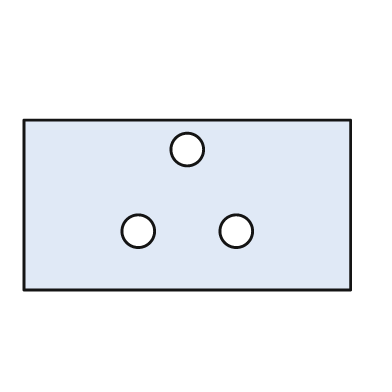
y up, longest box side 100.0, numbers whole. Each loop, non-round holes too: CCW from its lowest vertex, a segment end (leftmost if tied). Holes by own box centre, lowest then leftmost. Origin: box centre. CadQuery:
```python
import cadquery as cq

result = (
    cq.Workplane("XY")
    .moveTo(-50.0, -26.0)
    .lineTo(50.0, -26.0)
    .lineTo(50.0, 26.0)
    .lineTo(-50.0, 26.0)
    .close()
    .moveTo(-15.0, -8.0)
    .circle(5.0)
    .moveTo(15.0, -8.0)
    .circle(5.0)
    .moveTo(0.0, 17.0)
    .circle(5.0)
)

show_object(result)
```